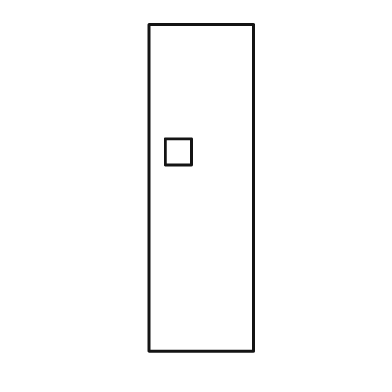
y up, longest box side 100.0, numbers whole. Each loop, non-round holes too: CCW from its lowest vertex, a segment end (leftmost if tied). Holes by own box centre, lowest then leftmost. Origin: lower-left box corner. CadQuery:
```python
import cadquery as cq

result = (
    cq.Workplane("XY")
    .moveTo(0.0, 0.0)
    .lineTo(32.0, 0.0)
    .lineTo(32.0, 100.0)
    .lineTo(0.0, 100.0)
    .close()
    .moveTo(5.0, 57.0)
    .lineTo(13.0, 57.0)
    .lineTo(13.0, 65.0)
    .lineTo(5.0, 65.0)
    .close()
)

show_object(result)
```